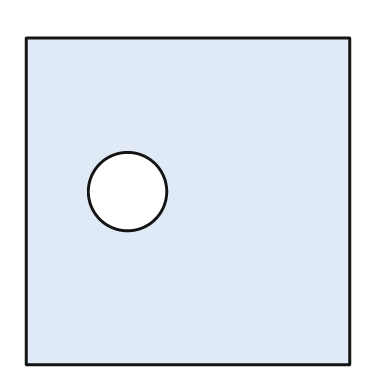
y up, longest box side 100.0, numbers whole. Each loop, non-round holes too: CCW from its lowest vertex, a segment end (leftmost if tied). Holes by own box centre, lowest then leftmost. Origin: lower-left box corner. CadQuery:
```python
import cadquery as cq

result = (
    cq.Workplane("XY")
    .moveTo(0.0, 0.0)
    .lineTo(99.0, 0.0)
    .lineTo(99.0, 100.0)
    .lineTo(0.0, 100.0)
    .close()
    .moveTo(31.0, 53.0)
    .circle(12.0)
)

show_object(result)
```